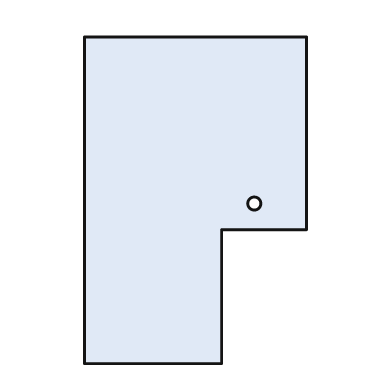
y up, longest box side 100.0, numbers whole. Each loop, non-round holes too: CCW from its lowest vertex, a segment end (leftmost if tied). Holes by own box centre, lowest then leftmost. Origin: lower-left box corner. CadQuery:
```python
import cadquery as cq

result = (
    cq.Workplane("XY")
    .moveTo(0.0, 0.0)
    .lineTo(42.0, 0.0)
    .lineTo(42.0, 41.0)
    .lineTo(68.0, 41.0)
    .lineTo(68.0, 100.0)
    .lineTo(0.0, 100.0)
    .close()
    .moveTo(52.0, 49.0)
    .circle(2.0)
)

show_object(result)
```